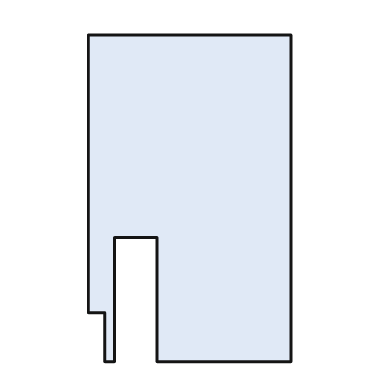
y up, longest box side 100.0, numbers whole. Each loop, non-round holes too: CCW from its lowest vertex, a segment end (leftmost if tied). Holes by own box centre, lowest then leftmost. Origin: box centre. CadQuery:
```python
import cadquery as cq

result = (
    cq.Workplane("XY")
    .moveTo(-26.0, -50.0)
    .lineTo(-23.0, -50.0)
    .lineTo(-23.0, -12.0)
    .lineTo(-10.0, -12.0)
    .lineTo(-10.0, -50.0)
    .lineTo(31.0, -50.0)
    .lineTo(31.0, 50.0)
    .lineTo(-31.0, 50.0)
    .lineTo(-31.0, -35.0)
    .lineTo(-26.0, -35.0)
    .close()
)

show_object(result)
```